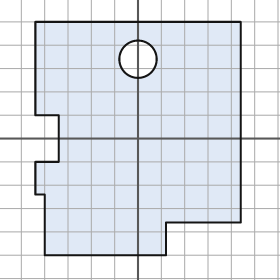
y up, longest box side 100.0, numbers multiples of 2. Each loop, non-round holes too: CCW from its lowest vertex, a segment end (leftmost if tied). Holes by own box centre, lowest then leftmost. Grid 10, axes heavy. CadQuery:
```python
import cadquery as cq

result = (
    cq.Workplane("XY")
    .moveTo(-40.0, -50.0)
    .lineTo(12.0, -50.0)
    .lineTo(12.0, -36.0)
    .lineTo(44.0, -36.0)
    .lineTo(44.0, 50.0)
    .lineTo(-44.0, 50.0)
    .lineTo(-44.0, 10.0)
    .lineTo(-34.0, 10.0)
    .lineTo(-34.0, -10.0)
    .lineTo(-44.0, -10.0)
    .lineTo(-44.0, -24.0)
    .lineTo(-40.0, -24.0)
    .close()
    .moveTo(0.0, 34.0)
    .circle(8.0)
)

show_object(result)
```